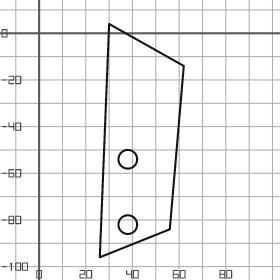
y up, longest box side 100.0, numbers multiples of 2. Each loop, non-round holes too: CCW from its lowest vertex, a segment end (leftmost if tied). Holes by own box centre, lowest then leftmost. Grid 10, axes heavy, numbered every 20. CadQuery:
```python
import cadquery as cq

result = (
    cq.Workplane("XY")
    .moveTo(26.0, -96.0)
    .lineTo(56.0, -84.0)
    .lineTo(62.0, -14.0)
    .lineTo(30.0, 4.0)
    .close()
    .moveTo(38.0, -82.0)
    .circle(4.0)
    .moveTo(38.0, -54.0)
    .circle(4.0)
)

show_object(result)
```